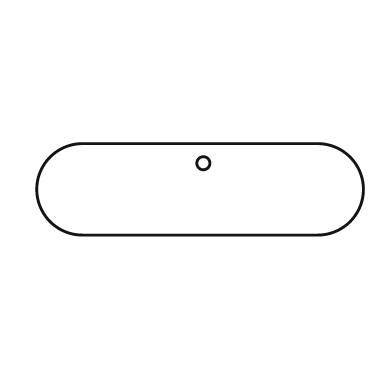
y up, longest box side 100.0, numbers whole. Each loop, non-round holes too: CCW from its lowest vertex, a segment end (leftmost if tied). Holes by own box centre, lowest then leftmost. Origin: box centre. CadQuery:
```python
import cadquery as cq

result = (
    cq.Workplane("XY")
    .moveTo(-36.0, -14.0)
    .lineTo(36.0, -14.0)
    .threePointArc((50.0, 0.0), (36.0, 14.0))
    .lineTo(-36.0, 14.0)
    .threePointArc((-50.0, 0.0), (-36.0, -14.0))
    .close()
    .moveTo(1.0, 8.0)
    .circle(2.0)
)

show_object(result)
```